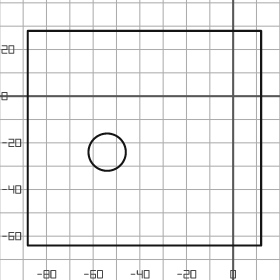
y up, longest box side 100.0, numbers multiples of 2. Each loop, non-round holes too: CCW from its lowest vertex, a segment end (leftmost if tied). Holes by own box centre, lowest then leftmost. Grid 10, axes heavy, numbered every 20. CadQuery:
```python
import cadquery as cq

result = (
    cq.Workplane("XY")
    .moveTo(-88.0, -64.0)
    .lineTo(12.0, -64.0)
    .lineTo(12.0, 28.0)
    .lineTo(-88.0, 28.0)
    .close()
    .moveTo(-54.0, -24.0)
    .circle(8.0)
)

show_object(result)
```